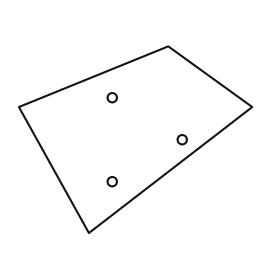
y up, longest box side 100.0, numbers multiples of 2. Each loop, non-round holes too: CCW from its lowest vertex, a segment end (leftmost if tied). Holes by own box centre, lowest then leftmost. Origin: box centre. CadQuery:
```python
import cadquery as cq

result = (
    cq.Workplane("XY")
    .moveTo(-20.0, -40.0)
    .lineTo(50.0, 14.0)
    .lineTo(14.0, 40.0)
    .lineTo(-50.0, 14.0)
    .close()
    .moveTo(-10.0, -18.0)
    .circle(2.0)
    .moveTo(20.0, 0.0)
    .circle(2.0)
    .moveTo(-10.0, 18.0)
    .circle(2.0)
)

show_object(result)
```